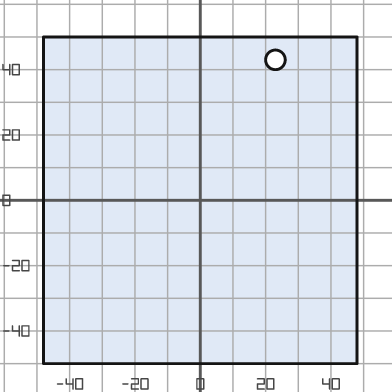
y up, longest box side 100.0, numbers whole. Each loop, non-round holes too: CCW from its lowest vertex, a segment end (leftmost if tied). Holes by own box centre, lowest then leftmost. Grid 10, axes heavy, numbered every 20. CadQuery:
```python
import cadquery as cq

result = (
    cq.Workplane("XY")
    .moveTo(-48.0, -50.0)
    .lineTo(48.0, -50.0)
    .lineTo(48.0, 50.0)
    .lineTo(-48.0, 50.0)
    .close()
    .moveTo(23.0, 43.0)
    .circle(3.0)
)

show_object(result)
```